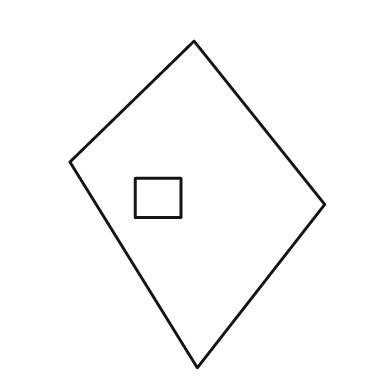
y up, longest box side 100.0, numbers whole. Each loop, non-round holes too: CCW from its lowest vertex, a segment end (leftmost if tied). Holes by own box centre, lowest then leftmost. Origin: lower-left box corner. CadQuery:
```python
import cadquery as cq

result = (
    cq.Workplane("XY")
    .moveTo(39.0, 0.0)
    .lineTo(78.0, 50.0)
    .lineTo(38.0, 100.0)
    .lineTo(0.0, 63.0)
    .close()
    .moveTo(20.0, 46.0)
    .lineTo(34.0, 46.0)
    .lineTo(34.0, 58.0)
    .lineTo(20.0, 58.0)
    .close()
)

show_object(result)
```